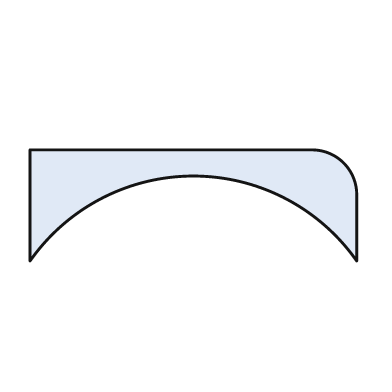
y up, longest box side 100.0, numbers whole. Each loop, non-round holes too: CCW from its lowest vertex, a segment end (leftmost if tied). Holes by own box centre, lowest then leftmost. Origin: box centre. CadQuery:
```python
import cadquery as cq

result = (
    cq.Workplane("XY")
    .moveTo(-50.0, -17.0)
    .threePointArc((0.0, 9.0), (50.0, -17.0))
    .lineTo(50.0, 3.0)
    .threePointArc((46.0, 13.0), (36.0, 17.0))
    .lineTo(-50.0, 17.0)
    .close()
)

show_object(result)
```